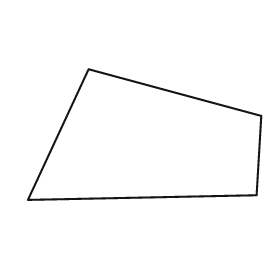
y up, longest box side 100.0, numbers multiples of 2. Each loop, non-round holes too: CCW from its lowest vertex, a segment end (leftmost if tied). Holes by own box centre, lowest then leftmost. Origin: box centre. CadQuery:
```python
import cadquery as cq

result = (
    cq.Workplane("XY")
    .moveTo(-50.0, -28.0)
    .lineTo(48.0, -26.0)
    .lineTo(50.0, 8.0)
    .lineTo(-24.0, 28.0)
    .close()
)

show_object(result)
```